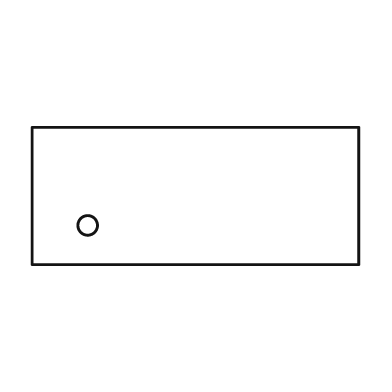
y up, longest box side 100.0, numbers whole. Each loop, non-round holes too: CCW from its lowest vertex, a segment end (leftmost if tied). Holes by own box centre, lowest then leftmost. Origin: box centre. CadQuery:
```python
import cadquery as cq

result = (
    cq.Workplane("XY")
    .moveTo(-50.0, -21.0)
    .lineTo(50.0, -21.0)
    .lineTo(50.0, 21.0)
    .lineTo(-50.0, 21.0)
    .close()
    .moveTo(-33.0, -9.0)
    .circle(3.0)
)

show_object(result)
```